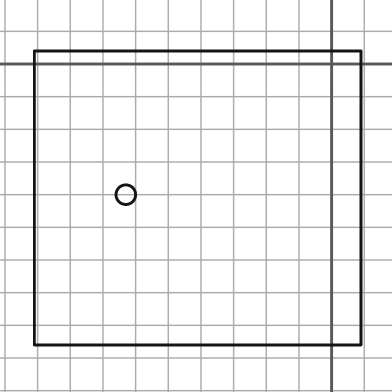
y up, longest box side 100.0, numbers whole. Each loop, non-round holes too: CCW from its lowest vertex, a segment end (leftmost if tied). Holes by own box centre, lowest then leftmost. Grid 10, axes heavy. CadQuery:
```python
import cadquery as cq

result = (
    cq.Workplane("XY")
    .moveTo(-91.0, -86.0)
    .lineTo(9.0, -86.0)
    .lineTo(9.0, 4.0)
    .lineTo(-91.0, 4.0)
    .close()
    .moveTo(-63.0, -40.0)
    .circle(3.0)
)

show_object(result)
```